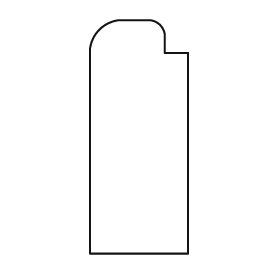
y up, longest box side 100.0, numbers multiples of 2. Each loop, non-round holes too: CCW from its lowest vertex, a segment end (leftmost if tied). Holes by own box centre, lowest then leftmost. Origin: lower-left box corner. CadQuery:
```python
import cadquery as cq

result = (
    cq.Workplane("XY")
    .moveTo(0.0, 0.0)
    .lineTo(42.0, 0.0)
    .lineTo(42.0, 86.0)
    .lineTo(32.0, 86.0)
    .lineTo(32.0, 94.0)
    .threePointArc((30.0, 98.0), (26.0, 100.0))
    .lineTo(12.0, 100.0)
    .threePointArc((4.0, 96.0), (0.0, 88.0))
    .close()
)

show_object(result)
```